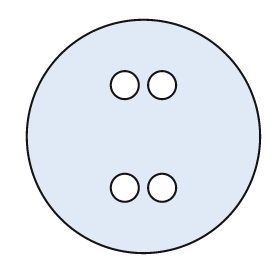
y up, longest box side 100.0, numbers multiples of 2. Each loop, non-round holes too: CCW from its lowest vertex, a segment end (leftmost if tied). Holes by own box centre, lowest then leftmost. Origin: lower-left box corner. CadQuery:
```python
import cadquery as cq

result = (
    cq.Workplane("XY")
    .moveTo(50.0, 50.0)
    .circle(50.0)
    .moveTo(42.0, 28.0)
    .circle(6.0)
    .moveTo(58.0, 28.0)
    .circle(6.0)
    .moveTo(42.0, 72.0)
    .circle(6.0)
    .moveTo(58.0, 72.0)
    .circle(6.0)
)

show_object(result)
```